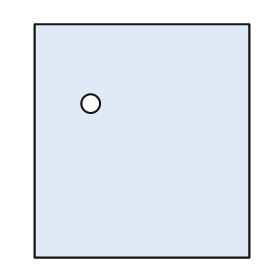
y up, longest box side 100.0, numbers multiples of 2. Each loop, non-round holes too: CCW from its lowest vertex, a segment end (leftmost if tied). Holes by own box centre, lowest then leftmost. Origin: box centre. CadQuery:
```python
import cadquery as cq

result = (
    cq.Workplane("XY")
    .moveTo(-46.0, -50.0)
    .lineTo(46.0, -50.0)
    .lineTo(46.0, 50.0)
    .lineTo(-46.0, 50.0)
    .close()
    .moveTo(-22.0, 16.0)
    .circle(4.0)
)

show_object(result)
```